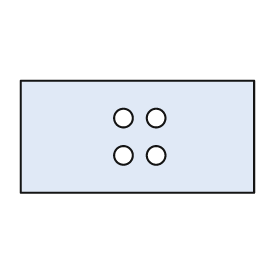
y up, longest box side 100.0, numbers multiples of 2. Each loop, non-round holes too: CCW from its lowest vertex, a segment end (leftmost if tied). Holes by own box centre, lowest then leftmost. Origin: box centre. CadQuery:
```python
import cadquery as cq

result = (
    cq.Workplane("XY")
    .moveTo(-50.0, -24.0)
    .lineTo(50.0, -24.0)
    .lineTo(50.0, 24.0)
    .lineTo(-50.0, 24.0)
    .close()
    .moveTo(-6.0, -8.0)
    .circle(4.0)
    .moveTo(8.0, -8.0)
    .circle(4.0)
    .moveTo(-6.0, 8.0)
    .circle(4.0)
    .moveTo(8.0, 8.0)
    .circle(4.0)
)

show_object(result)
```